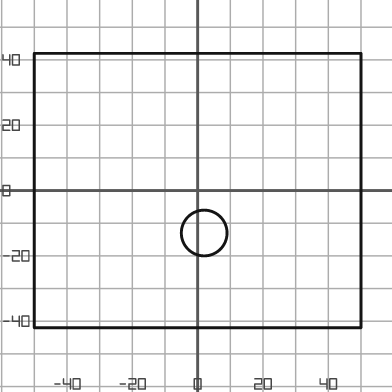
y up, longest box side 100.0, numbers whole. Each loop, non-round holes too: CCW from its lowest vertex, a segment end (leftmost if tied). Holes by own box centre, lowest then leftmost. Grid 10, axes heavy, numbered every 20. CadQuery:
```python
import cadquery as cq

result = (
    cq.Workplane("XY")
    .moveTo(-50.0, -42.0)
    .lineTo(50.0, -42.0)
    .lineTo(50.0, 42.0)
    .lineTo(-50.0, 42.0)
    .close()
    .moveTo(2.0, -13.0)
    .circle(7.0)
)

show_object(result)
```